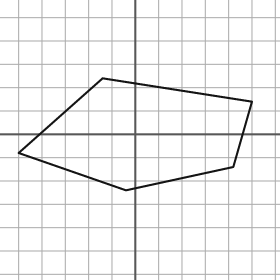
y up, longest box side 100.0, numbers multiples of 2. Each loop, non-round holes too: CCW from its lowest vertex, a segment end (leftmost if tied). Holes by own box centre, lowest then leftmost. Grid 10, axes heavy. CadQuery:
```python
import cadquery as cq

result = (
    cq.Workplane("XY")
    .moveTo(-4.0, -24.0)
    .lineTo(42.0, -14.0)
    .lineTo(50.0, 14.0)
    .lineTo(-14.0, 24.0)
    .lineTo(-50.0, -8.0)
    .close()
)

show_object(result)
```